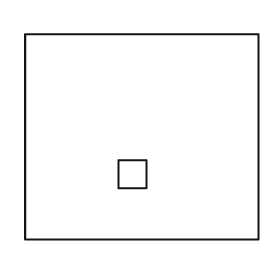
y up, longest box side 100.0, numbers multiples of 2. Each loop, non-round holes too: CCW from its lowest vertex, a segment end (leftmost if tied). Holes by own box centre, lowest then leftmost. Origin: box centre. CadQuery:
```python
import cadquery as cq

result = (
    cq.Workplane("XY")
    .moveTo(-50.0, -44.0)
    .lineTo(50.0, -44.0)
    .lineTo(50.0, 44.0)
    .lineTo(-50.0, 44.0)
    .close()
    .moveTo(-10.0, -22.0)
    .lineTo(2.0, -22.0)
    .lineTo(2.0, -10.0)
    .lineTo(-10.0, -10.0)
    .close()
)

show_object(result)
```